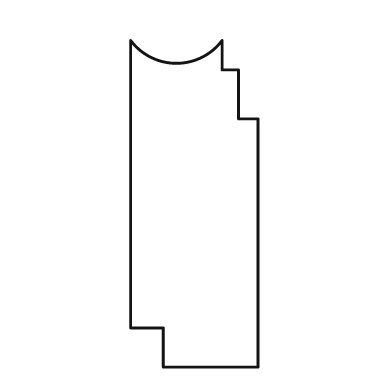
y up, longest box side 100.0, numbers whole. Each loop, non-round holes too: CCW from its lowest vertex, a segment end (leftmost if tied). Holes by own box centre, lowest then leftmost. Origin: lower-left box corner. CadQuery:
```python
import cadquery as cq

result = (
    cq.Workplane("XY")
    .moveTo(10.0, 0.0)
    .lineTo(39.0, 0.0)
    .lineTo(39.0, 76.0)
    .lineTo(33.0, 76.0)
    .lineTo(33.0, 91.0)
    .lineTo(28.0, 91.0)
    .lineTo(28.0, 100.0)
    .threePointArc((14.0, 93.0), (0.0, 100.0))
    .lineTo(0.0, 12.0)
    .lineTo(10.0, 12.0)
    .close()
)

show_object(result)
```